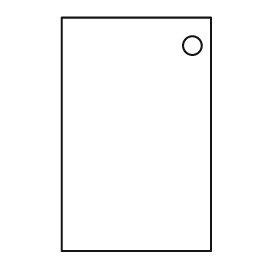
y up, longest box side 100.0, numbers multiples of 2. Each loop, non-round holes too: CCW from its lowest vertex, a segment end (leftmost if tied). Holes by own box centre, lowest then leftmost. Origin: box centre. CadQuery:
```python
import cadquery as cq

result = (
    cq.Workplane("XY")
    .moveTo(-32.0, -50.0)
    .lineTo(32.0, -50.0)
    .lineTo(32.0, 50.0)
    .lineTo(-32.0, 50.0)
    .close()
    .moveTo(24.0, 38.0)
    .circle(4.0)
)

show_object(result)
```